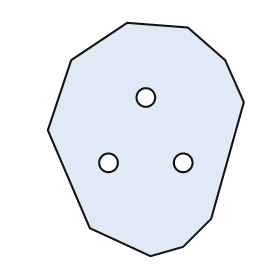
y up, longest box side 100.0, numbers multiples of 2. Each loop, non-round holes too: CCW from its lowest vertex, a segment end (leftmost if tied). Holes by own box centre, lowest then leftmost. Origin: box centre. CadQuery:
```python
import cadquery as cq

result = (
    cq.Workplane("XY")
    .moveTo(2.0, -50.0)
    .lineTo(16.0, -46.0)
    .lineTo(28.0, -34.0)
    .lineTo(42.0, 16.0)
    .lineTo(34.0, 34.0)
    .lineTo(18.0, 48.0)
    .lineTo(-8.0, 50.0)
    .lineTo(-32.0, 34.0)
    .lineTo(-42.0, 4.0)
    .lineTo(-24.0, -38.0)
    .close()
    .moveTo(-16.0, -10.0)
    .circle(4.0)
    .moveTo(16.0, -10.0)
    .circle(4.0)
    .moveTo(0.0, 18.0)
    .circle(4.0)
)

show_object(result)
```